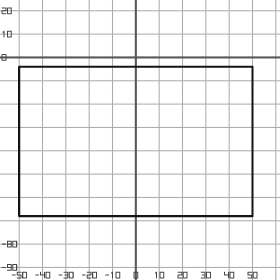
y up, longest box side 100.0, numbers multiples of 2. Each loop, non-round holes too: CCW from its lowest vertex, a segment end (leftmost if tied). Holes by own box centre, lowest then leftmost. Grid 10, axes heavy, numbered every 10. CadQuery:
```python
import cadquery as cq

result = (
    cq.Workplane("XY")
    .moveTo(-50.0, -68.0)
    .lineTo(50.0, -68.0)
    .lineTo(50.0, -4.0)
    .lineTo(-50.0, -4.0)
    .close()
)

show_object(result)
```